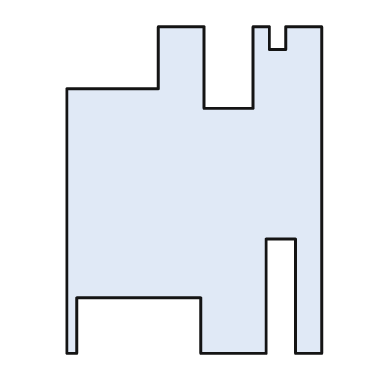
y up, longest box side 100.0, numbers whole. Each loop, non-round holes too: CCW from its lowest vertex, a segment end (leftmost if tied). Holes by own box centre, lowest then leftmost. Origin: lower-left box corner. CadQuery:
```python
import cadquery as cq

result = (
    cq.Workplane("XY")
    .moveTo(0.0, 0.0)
    .lineTo(3.0, 0.0)
    .lineTo(3.0, 17.0)
    .lineTo(41.0, 17.0)
    .lineTo(41.0, 0.0)
    .lineTo(61.0, 0.0)
    .lineTo(61.0, 35.0)
    .lineTo(70.0, 35.0)
    .lineTo(70.0, 0.0)
    .lineTo(78.0, 0.0)
    .lineTo(78.0, 100.0)
    .lineTo(67.0, 100.0)
    .lineTo(67.0, 93.0)
    .lineTo(62.0, 93.0)
    .lineTo(62.0, 100.0)
    .lineTo(57.0, 100.0)
    .lineTo(57.0, 75.0)
    .lineTo(42.0, 75.0)
    .lineTo(42.0, 100.0)
    .lineTo(28.0, 100.0)
    .lineTo(28.0, 81.0)
    .lineTo(0.0, 81.0)
    .close()
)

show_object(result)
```